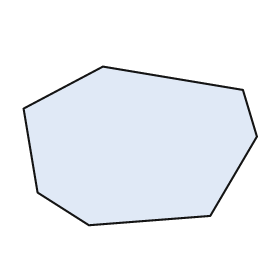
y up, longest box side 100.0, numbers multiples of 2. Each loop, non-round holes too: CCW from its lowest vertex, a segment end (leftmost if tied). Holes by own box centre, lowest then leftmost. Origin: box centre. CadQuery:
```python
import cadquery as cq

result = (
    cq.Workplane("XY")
    .moveTo(-22.0, -34.0)
    .lineTo(30.0, -30.0)
    .lineTo(50.0, 4.0)
    .lineTo(44.0, 24.0)
    .lineTo(-16.0, 34.0)
    .lineTo(-50.0, 16.0)
    .lineTo(-44.0, -20.0)
    .close()
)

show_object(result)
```